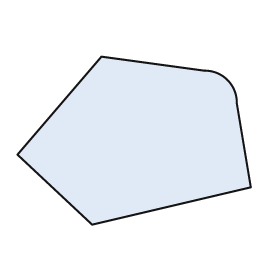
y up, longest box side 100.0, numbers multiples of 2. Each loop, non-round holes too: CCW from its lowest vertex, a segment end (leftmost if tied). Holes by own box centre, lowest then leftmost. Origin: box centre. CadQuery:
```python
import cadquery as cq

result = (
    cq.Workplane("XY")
    .moveTo(-18.0, -36.0)
    .lineTo(50.0, -20.0)
    .lineTo(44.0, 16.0)
    .threePointArc((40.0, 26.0), (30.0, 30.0))
    .lineTo(-14.0, 36.0)
    .lineTo(-50.0, -6.0)
    .close()
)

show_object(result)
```